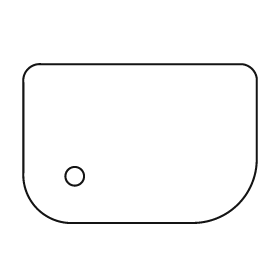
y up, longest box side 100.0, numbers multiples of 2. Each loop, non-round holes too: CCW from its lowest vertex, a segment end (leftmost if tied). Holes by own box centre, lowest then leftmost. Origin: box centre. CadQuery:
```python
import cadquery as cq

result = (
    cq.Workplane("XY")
    .moveTo(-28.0, -34.0)
    .lineTo(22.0, -34.0)
    .threePointArc((42.0, -26.0), (50.0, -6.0))
    .lineTo(50.0, 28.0)
    .threePointArc((48.0, 32.0), (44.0, 34.0))
    .lineTo(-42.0, 34.0)
    .threePointArc((-48.0, 32.0), (-50.0, 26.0))
    .lineTo(-50.0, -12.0)
    .threePointArc((-44.0, -28.0), (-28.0, -34.0))
    .close()
    .moveTo(-28.0, -14.0)
    .circle(4.0)
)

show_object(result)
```